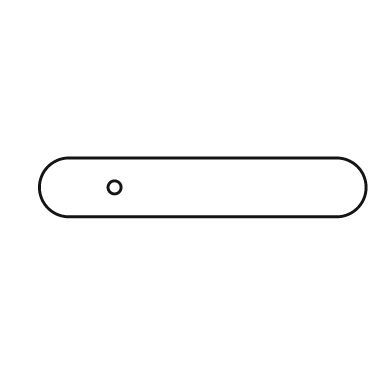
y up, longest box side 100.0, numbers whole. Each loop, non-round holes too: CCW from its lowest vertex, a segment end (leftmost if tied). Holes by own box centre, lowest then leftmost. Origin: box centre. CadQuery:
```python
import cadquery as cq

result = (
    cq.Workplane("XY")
    .moveTo(-41.0, -9.0)
    .lineTo(41.0, -9.0)
    .threePointArc((50.0, 0.0), (41.0, 9.0))
    .lineTo(-41.0, 9.0)
    .threePointArc((-50.0, 0.0), (-41.0, -9.0))
    .close()
    .moveTo(-27.0, 0.0)
    .circle(2.0)
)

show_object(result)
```